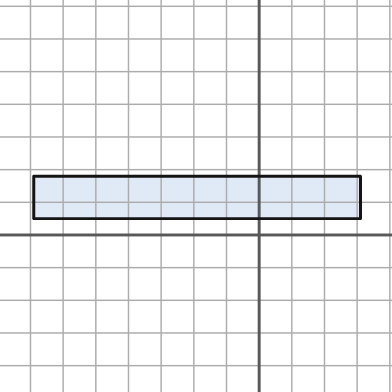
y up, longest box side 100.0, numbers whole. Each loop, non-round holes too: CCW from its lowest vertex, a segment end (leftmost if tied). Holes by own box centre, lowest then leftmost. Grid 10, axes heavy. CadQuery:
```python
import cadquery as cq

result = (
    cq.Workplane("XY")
    .moveTo(-69.0, 5.0)
    .lineTo(31.0, 5.0)
    .lineTo(31.0, 18.0)
    .lineTo(-69.0, 18.0)
    .close()
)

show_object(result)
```